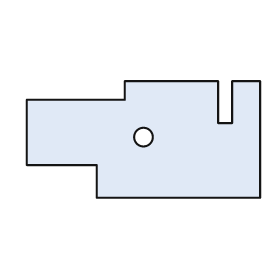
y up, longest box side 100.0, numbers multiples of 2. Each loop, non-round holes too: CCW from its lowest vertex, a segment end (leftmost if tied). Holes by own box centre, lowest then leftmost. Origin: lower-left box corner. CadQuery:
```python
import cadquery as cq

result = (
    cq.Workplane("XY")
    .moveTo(30.0, 0.0)
    .lineTo(100.0, 0.0)
    .lineTo(100.0, 50.0)
    .lineTo(88.0, 50.0)
    .lineTo(88.0, 32.0)
    .lineTo(82.0, 32.0)
    .lineTo(82.0, 50.0)
    .lineTo(42.0, 50.0)
    .lineTo(42.0, 42.0)
    .lineTo(0.0, 42.0)
    .lineTo(0.0, 14.0)
    .lineTo(30.0, 14.0)
    .close()
    .moveTo(50.0, 26.0)
    .circle(4.0)
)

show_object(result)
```